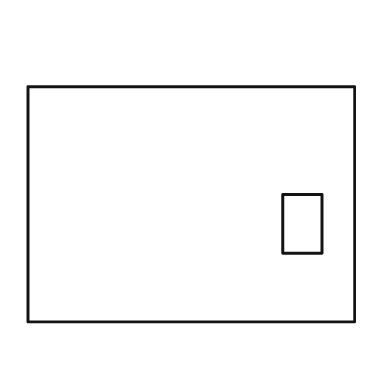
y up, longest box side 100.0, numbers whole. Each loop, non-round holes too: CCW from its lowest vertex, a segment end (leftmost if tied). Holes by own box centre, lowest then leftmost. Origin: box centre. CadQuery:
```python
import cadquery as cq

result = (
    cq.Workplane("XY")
    .moveTo(-50.0, -36.0)
    .lineTo(50.0, -36.0)
    .lineTo(50.0, 36.0)
    .lineTo(-50.0, 36.0)
    .close()
    .moveTo(28.0, -15.0)
    .lineTo(40.0, -15.0)
    .lineTo(40.0, 3.0)
    .lineTo(28.0, 3.0)
    .close()
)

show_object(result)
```